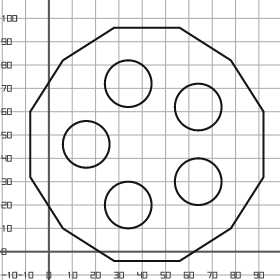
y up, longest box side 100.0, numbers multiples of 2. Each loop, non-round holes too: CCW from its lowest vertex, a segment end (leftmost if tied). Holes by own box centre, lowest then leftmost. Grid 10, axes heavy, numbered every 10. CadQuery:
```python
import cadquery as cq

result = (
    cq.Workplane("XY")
    .moveTo(28.0, -4.0)
    .lineTo(56.0, -4.0)
    .lineTo(78.0, 10.0)
    .lineTo(92.0, 32.0)
    .lineTo(92.0, 60.0)
    .lineTo(78.0, 82.0)
    .lineTo(56.0, 96.0)
    .lineTo(28.0, 96.0)
    .lineTo(6.0, 82.0)
    .lineTo(-8.0, 60.0)
    .lineTo(-8.0, 32.0)
    .lineTo(6.0, 10.0)
    .close()
    .moveTo(34.0, 20.0)
    .circle(10.0)
    .moveTo(64.0, 30.0)
    .circle(10.0)
    .moveTo(16.0, 46.0)
    .circle(10.0)
    .moveTo(64.0, 62.0)
    .circle(10.0)
    .moveTo(34.0, 72.0)
    .circle(10.0)
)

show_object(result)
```